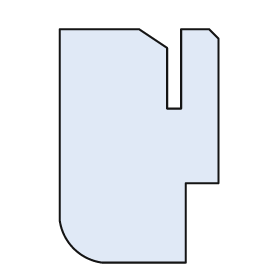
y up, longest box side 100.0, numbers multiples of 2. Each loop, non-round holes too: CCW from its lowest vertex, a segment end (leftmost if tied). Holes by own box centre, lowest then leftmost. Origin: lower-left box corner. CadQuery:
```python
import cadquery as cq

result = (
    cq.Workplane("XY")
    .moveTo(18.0, 0.0)
    .lineTo(54.0, 0.0)
    .lineTo(54.0, 34.0)
    .lineTo(68.0, 34.0)
    .lineTo(68.0, 96.0)
    .lineTo(64.0, 100.0)
    .lineTo(52.0, 100.0)
    .lineTo(52.0, 66.0)
    .lineTo(46.0, 66.0)
    .lineTo(46.0, 92.0)
    .lineTo(34.0, 100.0)
    .lineTo(0.0, 100.0)
    .lineTo(0.0, 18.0)
    .threePointArc((6.0, 6.0), (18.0, 0.0))
    .close()
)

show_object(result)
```